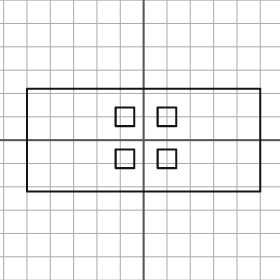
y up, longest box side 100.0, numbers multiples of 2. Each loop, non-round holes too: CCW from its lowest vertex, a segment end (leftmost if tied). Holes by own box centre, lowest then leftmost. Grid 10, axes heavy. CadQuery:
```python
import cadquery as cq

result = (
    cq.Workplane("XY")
    .moveTo(-50.0, -22.0)
    .lineTo(50.0, -22.0)
    .lineTo(50.0, 22.0)
    .lineTo(-50.0, 22.0)
    .close()
    .moveTo(-12.0, -12.0)
    .lineTo(-4.0, -12.0)
    .lineTo(-4.0, -4.0)
    .lineTo(-12.0, -4.0)
    .close()
    .moveTo(6.0, -12.0)
    .lineTo(14.0, -12.0)
    .lineTo(14.0, -4.0)
    .lineTo(6.0, -4.0)
    .close()
    .moveTo(-12.0, 6.0)
    .lineTo(-4.0, 6.0)
    .lineTo(-4.0, 14.0)
    .lineTo(-12.0, 14.0)
    .close()
    .moveTo(6.0, 6.0)
    .lineTo(14.0, 6.0)
    .lineTo(14.0, 14.0)
    .lineTo(6.0, 14.0)
    .close()
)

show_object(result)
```